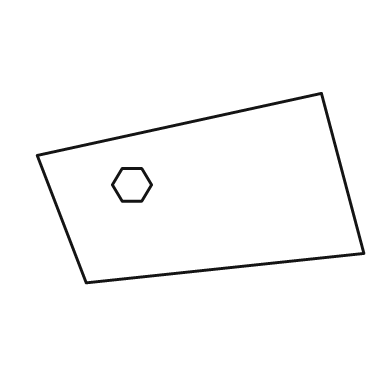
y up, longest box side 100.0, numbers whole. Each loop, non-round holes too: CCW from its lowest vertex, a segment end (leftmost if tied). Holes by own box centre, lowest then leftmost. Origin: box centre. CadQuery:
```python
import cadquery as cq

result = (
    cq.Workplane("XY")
    .moveTo(-35.0, -29.0)
    .lineTo(50.0, -20.0)
    .lineTo(37.0, 29.0)
    .lineTo(-50.0, 10.0)
    .close()
    .moveTo(-24.0, -4.0)
    .lineTo(-18.0, -4.0)
    .lineTo(-15.0, 1.0)
    .lineTo(-18.0, 6.0)
    .lineTo(-24.0, 6.0)
    .lineTo(-27.0, 1.0)
    .close()
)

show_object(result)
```